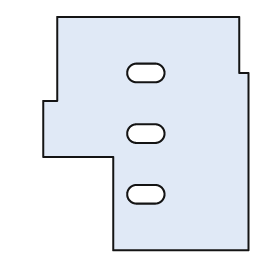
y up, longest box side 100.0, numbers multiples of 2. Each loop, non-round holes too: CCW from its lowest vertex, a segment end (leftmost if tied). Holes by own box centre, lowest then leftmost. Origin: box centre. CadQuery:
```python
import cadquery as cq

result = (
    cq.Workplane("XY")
    .moveTo(-14.0, -50.0)
    .lineTo(44.0, -50.0)
    .lineTo(44.0, 26.0)
    .lineTo(40.0, 26.0)
    .lineTo(40.0, 50.0)
    .lineTo(-38.0, 50.0)
    .lineTo(-38.0, 14.0)
    .lineTo(-44.0, 14.0)
    .lineTo(-44.0, -10.0)
    .lineTo(-14.0, -10.0)
    .close()
    .moveTo(-4.0, -30.0)
    .lineTo(4.0, -30.0)
    .threePointArc((8.0, -26.0), (4.0, -22.0))
    .lineTo(-4.0, -22.0)
    .threePointArc((-8.0, -26.0), (-4.0, -30.0))
    .close()
    .moveTo(-4.0, -4.0)
    .lineTo(4.0, -4.0)
    .threePointArc((8.0, 0.0), (4.0, 4.0))
    .lineTo(-4.0, 4.0)
    .threePointArc((-8.0, 0.0), (-4.0, -4.0))
    .close()
    .moveTo(-4.0, 22.0)
    .lineTo(4.0, 22.0)
    .threePointArc((8.0, 26.0), (4.0, 30.0))
    .lineTo(-4.0, 30.0)
    .threePointArc((-8.0, 26.0), (-4.0, 22.0))
    .close()
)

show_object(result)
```